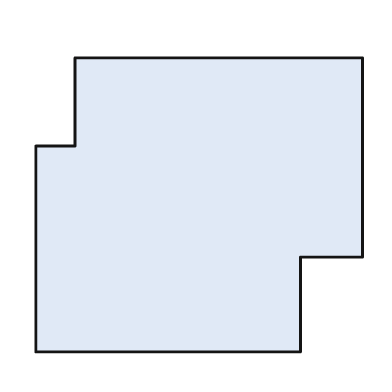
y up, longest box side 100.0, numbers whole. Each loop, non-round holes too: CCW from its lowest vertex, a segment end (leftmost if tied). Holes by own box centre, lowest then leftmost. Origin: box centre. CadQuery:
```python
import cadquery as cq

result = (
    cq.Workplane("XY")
    .moveTo(-50.0, -45.0)
    .lineTo(31.0, -45.0)
    .lineTo(31.0, -16.0)
    .lineTo(50.0, -16.0)
    .lineTo(50.0, 45.0)
    .lineTo(-38.0, 45.0)
    .lineTo(-38.0, 18.0)
    .lineTo(-50.0, 18.0)
    .close()
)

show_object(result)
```